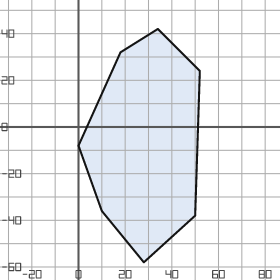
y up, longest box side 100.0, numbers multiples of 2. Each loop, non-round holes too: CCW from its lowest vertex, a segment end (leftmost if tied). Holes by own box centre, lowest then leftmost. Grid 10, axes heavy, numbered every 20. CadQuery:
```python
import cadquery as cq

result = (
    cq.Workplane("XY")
    .moveTo(28.0, -58.0)
    .lineTo(50.0, -38.0)
    .lineTo(52.0, 24.0)
    .lineTo(34.0, 42.0)
    .lineTo(18.0, 32.0)
    .lineTo(0.0, -8.0)
    .lineTo(10.0, -36.0)
    .close()
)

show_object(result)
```